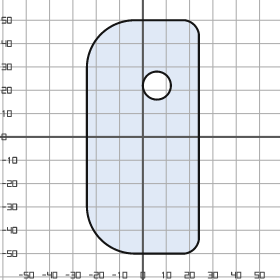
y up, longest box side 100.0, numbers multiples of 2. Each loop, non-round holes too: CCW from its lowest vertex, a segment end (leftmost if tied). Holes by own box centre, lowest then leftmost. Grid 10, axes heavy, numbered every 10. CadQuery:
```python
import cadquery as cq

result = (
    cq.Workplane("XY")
    .moveTo(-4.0, -50.0)
    .lineTo(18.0, -50.0)
    .threePointArc((22.0, -48.0), (24.0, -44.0))
    .lineTo(24.0, 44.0)
    .threePointArc((22.0, 48.0), (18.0, 50.0))
    .lineTo(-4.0, 50.0)
    .threePointArc((-18.0, 44.0), (-24.0, 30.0))
    .lineTo(-24.0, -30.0)
    .threePointArc((-18.0, -44.0), (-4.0, -50.0))
    .close()
    .moveTo(6.0, 22.0)
    .circle(6.0)
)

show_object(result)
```